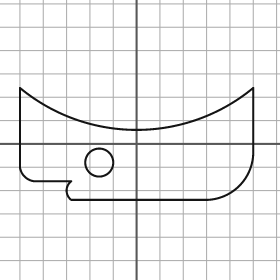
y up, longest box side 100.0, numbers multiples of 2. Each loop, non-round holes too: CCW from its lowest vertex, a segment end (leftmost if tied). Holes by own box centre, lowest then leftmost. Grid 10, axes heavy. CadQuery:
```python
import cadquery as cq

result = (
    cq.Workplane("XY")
    .moveTo(-28.0, -24.0)
    .lineTo(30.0, -24.0)
    .threePointArc((44.0, -18.0), (50.0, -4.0))
    .lineTo(50.0, 24.0)
    .threePointArc((0.0, 6.0), (-50.0, 24.0))
    .lineTo(-50.0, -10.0)
    .threePointArc((-48.0, -14.0), (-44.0, -16.0))
    .lineTo(-28.0, -16.0)
    .threePointArc((-30.0, -20.0), (-28.0, -24.0))
    .close()
    .moveTo(-16.0, -8.0)
    .circle(6.0)
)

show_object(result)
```